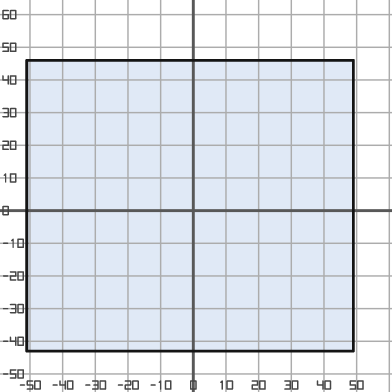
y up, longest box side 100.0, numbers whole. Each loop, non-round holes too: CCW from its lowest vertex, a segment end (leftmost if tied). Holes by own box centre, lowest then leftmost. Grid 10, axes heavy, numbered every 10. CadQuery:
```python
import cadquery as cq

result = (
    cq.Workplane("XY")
    .moveTo(-51.0, -43.0)
    .lineTo(49.0, -43.0)
    .lineTo(49.0, 46.0)
    .lineTo(-51.0, 46.0)
    .close()
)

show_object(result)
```